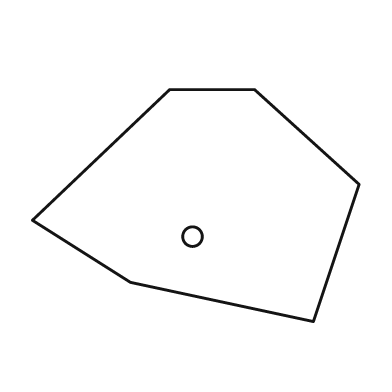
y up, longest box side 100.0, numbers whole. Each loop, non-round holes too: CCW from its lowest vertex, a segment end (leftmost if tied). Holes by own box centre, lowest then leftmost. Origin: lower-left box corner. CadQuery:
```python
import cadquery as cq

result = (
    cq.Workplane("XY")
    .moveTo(86.0, 0.0)
    .lineTo(100.0, 42.0)
    .lineTo(68.0, 71.0)
    .lineTo(42.0, 71.0)
    .lineTo(0.0, 31.0)
    .lineTo(30.0, 12.0)
    .close()
    .moveTo(49.0, 26.0)
    .circle(3.0)
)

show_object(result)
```